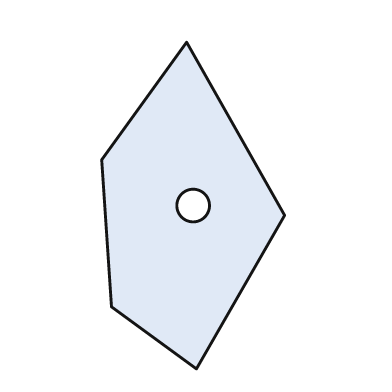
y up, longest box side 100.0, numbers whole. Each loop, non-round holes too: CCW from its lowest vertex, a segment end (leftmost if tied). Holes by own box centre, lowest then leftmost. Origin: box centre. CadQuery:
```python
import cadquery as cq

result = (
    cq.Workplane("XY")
    .moveTo(1.0, -50.0)
    .lineTo(28.0, -3.0)
    .lineTo(-2.0, 50.0)
    .lineTo(-28.0, 14.0)
    .lineTo(-25.0, -31.0)
    .close()
    .moveTo(0.0, 0.0)
    .circle(5.0)
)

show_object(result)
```